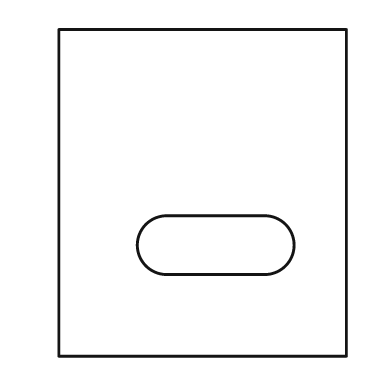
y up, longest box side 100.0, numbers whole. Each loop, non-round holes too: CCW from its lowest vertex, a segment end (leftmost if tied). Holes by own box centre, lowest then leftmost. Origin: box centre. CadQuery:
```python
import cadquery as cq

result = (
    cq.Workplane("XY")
    .moveTo(-44.0, -50.0)
    .lineTo(44.0, -50.0)
    .lineTo(44.0, 50.0)
    .lineTo(-44.0, 50.0)
    .close()
    .moveTo(-11.0, -25.0)
    .lineTo(19.0, -25.0)
    .threePointArc((28.0, -16.0), (19.0, -7.0))
    .lineTo(-11.0, -7.0)
    .threePointArc((-20.0, -16.0), (-11.0, -25.0))
    .close()
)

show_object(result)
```